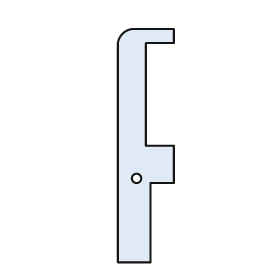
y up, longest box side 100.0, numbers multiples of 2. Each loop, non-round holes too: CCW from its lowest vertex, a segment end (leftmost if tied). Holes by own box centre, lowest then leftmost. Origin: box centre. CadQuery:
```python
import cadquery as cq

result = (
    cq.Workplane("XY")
    .moveTo(-12.0, -50.0)
    .lineTo(2.0, -50.0)
    .lineTo(2.0, -16.0)
    .lineTo(12.0, -16.0)
    .lineTo(12.0, 0.0)
    .lineTo(0.0, 0.0)
    .lineTo(0.0, 44.0)
    .lineTo(12.0, 44.0)
    .lineTo(12.0, 50.0)
    .lineTo(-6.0, 50.0)
    .threePointArc((-10.0, 48.0), (-12.0, 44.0))
    .close()
    .moveTo(-4.0, -14.0)
    .circle(2.0)
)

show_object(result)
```